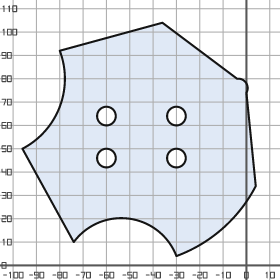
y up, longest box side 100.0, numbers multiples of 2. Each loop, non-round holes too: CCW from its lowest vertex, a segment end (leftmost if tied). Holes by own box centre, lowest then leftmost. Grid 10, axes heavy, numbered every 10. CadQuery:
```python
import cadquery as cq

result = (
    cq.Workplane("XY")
    .moveTo(-30.0, 4.0)
    .threePointArc((-10.0, 16.0), (4.0, 34.0))
    .lineTo(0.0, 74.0)
    .threePointArc((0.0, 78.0), (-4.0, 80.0))
    .lineTo(-36.0, 104.0)
    .lineTo(-80.0, 92.0)
    .threePointArc((-80.0, 68.0), (-96.0, 50.0))
    .lineTo(-74.0, 10.0)
    .threePointArc((-50.0, 20.0), (-30.0, 4.0))
    .close()
    .moveTo(-60.0, 46.0)
    .circle(4.0)
    .moveTo(-30.0, 46.0)
    .circle(4.0)
    .moveTo(-60.0, 64.0)
    .circle(4.0)
    .moveTo(-30.0, 64.0)
    .circle(4.0)
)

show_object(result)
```